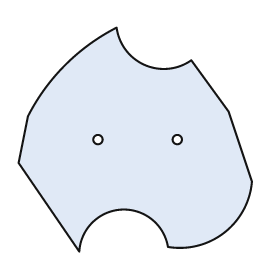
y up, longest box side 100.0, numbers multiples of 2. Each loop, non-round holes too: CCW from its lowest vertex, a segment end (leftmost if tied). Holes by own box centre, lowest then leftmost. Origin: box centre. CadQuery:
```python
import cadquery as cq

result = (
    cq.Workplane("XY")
    .moveTo(-24.0, -48.0)
    .threePointArc((-6.0, -30.0), (14.0, -46.0))
    .threePointArc((38.0, -40.0), (50.0, -18.0))
    .lineTo(40.0, 12.0)
    .lineTo(24.0, 34.0)
    .threePointArc((4.0, 32.0), (-8.0, 48.0))
    .threePointArc((-30.0, 32.0), (-46.0, 10.0))
    .lineTo(-50.0, -10.0)
    .close()
    .moveTo(-16.0, 0.0)
    .circle(2.0)
    .moveTo(18.0, 0.0)
    .circle(2.0)
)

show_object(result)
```